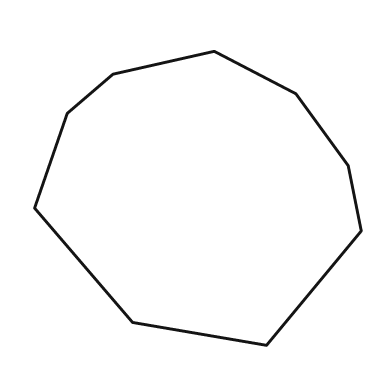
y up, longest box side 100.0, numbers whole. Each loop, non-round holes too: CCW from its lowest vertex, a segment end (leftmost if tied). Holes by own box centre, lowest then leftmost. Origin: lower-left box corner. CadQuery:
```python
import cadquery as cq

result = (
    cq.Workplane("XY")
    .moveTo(71.0, 0.0)
    .lineTo(100.0, 35.0)
    .lineTo(96.0, 55.0)
    .lineTo(80.0, 77.0)
    .lineTo(55.0, 90.0)
    .lineTo(24.0, 83.0)
    .lineTo(10.0, 71.0)
    .lineTo(0.0, 42.0)
    .lineTo(30.0, 7.0)
    .close()
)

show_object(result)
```